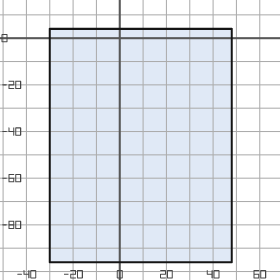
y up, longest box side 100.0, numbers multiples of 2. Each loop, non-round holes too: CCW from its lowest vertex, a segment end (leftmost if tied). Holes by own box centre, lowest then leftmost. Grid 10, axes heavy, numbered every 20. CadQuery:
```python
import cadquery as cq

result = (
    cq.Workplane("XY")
    .moveTo(-30.0, -96.0)
    .lineTo(48.0, -96.0)
    .lineTo(48.0, 4.0)
    .lineTo(-30.0, 4.0)
    .close()
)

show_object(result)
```